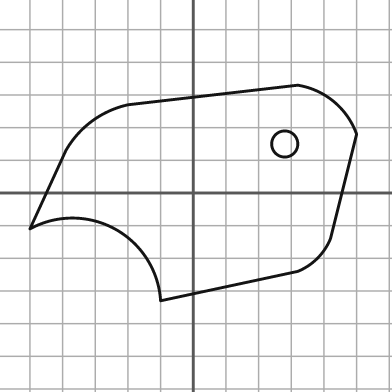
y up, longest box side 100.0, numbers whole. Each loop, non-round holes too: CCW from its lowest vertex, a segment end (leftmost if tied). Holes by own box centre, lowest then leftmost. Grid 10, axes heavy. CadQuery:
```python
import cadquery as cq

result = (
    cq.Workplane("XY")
    .moveTo(-10.0, -33.0)
    .lineTo(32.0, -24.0)
    .threePointArc((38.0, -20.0), (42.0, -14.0))
    .lineTo(50.0, 18.0)
    .threePointArc((43.0, 28.0), (32.0, 33.0))
    .lineTo(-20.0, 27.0)
    .threePointArc((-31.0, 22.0), (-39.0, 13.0))
    .lineTo(-50.0, -11.0)
    .threePointArc((-24.0, -11.0), (-10.0, -33.0))
    .close()
    .moveTo(28.0, 15.0)
    .circle(4.0)
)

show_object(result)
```